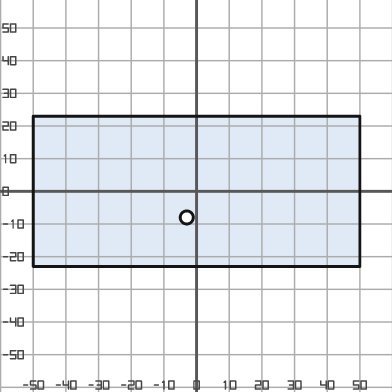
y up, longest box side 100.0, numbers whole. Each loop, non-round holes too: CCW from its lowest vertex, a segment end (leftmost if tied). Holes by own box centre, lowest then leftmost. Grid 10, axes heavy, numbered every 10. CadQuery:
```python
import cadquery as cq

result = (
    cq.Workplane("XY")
    .moveTo(-50.0, -23.0)
    .lineTo(50.0, -23.0)
    .lineTo(50.0, 23.0)
    .lineTo(-50.0, 23.0)
    .close()
    .moveTo(-3.0, -8.0)
    .circle(2.0)
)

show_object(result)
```